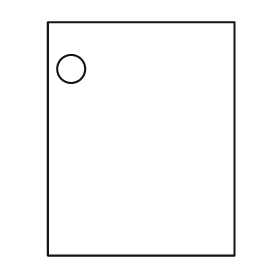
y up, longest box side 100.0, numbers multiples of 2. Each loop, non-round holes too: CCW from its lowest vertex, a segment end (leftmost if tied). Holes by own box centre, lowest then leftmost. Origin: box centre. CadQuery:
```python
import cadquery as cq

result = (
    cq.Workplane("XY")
    .moveTo(-40.0, -50.0)
    .lineTo(40.0, -50.0)
    .lineTo(40.0, 50.0)
    .lineTo(-40.0, 50.0)
    .close()
    .moveTo(-30.0, 30.0)
    .circle(6.0)
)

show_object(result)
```